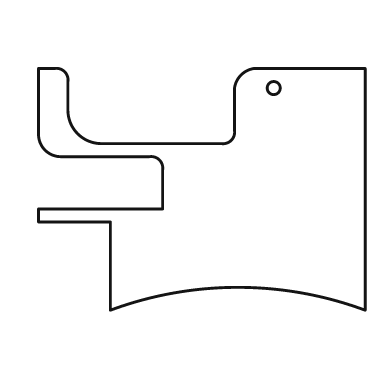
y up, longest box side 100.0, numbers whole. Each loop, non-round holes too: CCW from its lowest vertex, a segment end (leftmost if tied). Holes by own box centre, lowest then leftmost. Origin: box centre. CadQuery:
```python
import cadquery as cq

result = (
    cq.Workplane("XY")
    .moveTo(-28.0, -37.0)
    .threePointArc((11.0, -30.0), (50.0, -37.0))
    .lineTo(50.0, 37.0)
    .lineTo(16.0, 37.0)
    .threePointArc((12.0, 35.0), (10.0, 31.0))
    .lineTo(10.0, 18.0)
    .threePointArc((9.0, 15.0), (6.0, 14.0))
    .lineTo(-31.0, 14.0)
    .threePointArc((-38.0, 17.0), (-41.0, 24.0))
    .lineTo(-41.0, 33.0)
    .threePointArc((-42.0, 36.0), (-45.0, 37.0))
    .lineTo(-50.0, 37.0)
    .lineTo(-50.0, 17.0)
    .threePointArc((-48.0, 12.0), (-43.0, 10.0))
    .lineTo(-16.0, 10.0)
    .threePointArc((-13.0, 9.0), (-12.0, 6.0))
    .lineTo(-12.0, -6.0)
    .lineTo(-50.0, -6.0)
    .lineTo(-50.0, -10.0)
    .lineTo(-28.0, -10.0)
    .close()
    .moveTo(22.0, 31.0)
    .circle(2.0)
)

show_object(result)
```